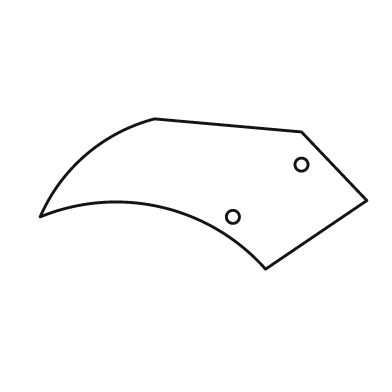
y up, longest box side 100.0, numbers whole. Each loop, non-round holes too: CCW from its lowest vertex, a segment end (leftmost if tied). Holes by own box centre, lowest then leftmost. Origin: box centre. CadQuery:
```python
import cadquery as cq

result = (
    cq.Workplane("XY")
    .moveTo(19.0, -23.0)
    .lineTo(50.0, -2.0)
    .lineTo(30.0, 19.0)
    .lineTo(-15.0, 23.0)
    .threePointArc((-36.0, 12.0), (-50.0, -7.0))
    .threePointArc((-13.0, -4.0), (19.0, -23.0))
    .close()
    .moveTo(9.0, -7.0)
    .circle(2.0)
    .moveTo(30.0, 9.0)
    .circle(2.0)
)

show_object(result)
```